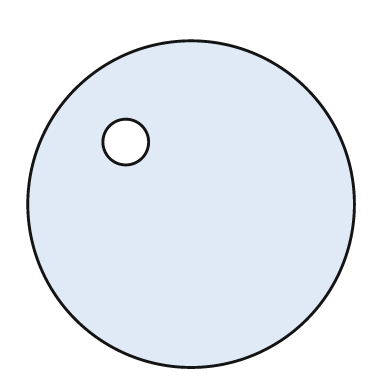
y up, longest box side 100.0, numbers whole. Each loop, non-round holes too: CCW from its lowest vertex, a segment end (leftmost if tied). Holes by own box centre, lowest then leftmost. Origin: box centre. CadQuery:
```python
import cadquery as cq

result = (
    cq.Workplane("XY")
    .moveTo(0.0, 0.0)
    .circle(50.0)
    .moveTo(-20.0, 19.0)
    .circle(7.0)
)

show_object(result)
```